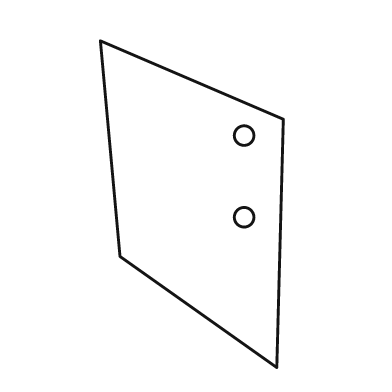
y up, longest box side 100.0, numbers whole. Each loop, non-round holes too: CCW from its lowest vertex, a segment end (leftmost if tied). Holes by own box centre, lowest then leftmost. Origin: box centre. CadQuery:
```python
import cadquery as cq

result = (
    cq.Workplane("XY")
    .moveTo(26.0, -50.0)
    .lineTo(28.0, 26.0)
    .lineTo(-28.0, 50.0)
    .lineTo(-22.0, -16.0)
    .close()
    .moveTo(16.0, -4.0)
    .circle(3.0)
    .moveTo(16.0, 21.0)
    .circle(3.0)
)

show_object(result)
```